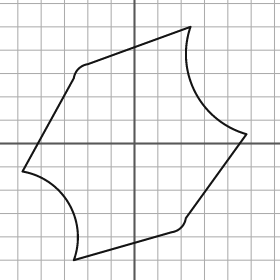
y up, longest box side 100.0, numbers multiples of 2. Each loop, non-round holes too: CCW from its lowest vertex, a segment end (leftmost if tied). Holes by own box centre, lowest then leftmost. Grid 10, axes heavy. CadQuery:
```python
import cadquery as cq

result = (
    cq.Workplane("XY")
    .moveTo(-26.0, -50.0)
    .lineTo(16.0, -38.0)
    .threePointArc((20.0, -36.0), (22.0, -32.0))
    .lineTo(48.0, 4.0)
    .threePointArc((26.0, 22.0), (24.0, 50.0))
    .lineTo(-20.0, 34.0)
    .threePointArc((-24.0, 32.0), (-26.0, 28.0))
    .lineTo(-48.0, -12.0)
    .threePointArc((-28.0, -26.0), (-26.0, -50.0))
    .close()
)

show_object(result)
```